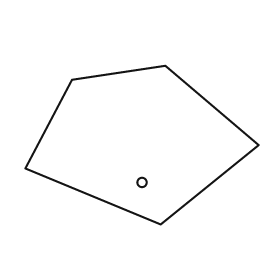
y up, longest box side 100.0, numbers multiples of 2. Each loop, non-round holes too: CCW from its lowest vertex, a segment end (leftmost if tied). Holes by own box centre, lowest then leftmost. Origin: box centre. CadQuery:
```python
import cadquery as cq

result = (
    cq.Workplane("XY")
    .moveTo(8.0, -34.0)
    .lineTo(50.0, 0.0)
    .lineTo(10.0, 34.0)
    .lineTo(-30.0, 28.0)
    .lineTo(-50.0, -10.0)
    .close()
    .moveTo(0.0, -16.0)
    .circle(2.0)
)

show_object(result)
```